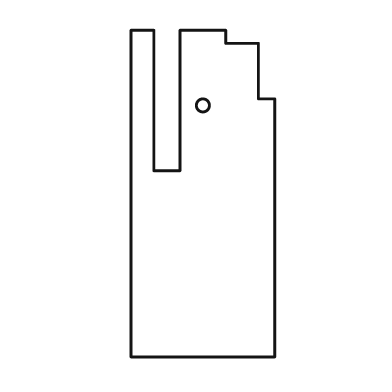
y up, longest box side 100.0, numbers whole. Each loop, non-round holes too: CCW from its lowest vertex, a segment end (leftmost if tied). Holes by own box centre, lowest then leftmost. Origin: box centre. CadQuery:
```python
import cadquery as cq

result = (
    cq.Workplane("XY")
    .moveTo(-22.0, -50.0)
    .lineTo(22.0, -50.0)
    .lineTo(22.0, 29.0)
    .lineTo(17.0, 29.0)
    .lineTo(17.0, 46.0)
    .lineTo(7.0, 46.0)
    .lineTo(7.0, 50.0)
    .lineTo(-7.0, 50.0)
    .lineTo(-7.0, 7.0)
    .lineTo(-15.0, 7.0)
    .lineTo(-15.0, 50.0)
    .lineTo(-22.0, 50.0)
    .close()
    .moveTo(0.0, 27.0)
    .circle(2.0)
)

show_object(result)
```